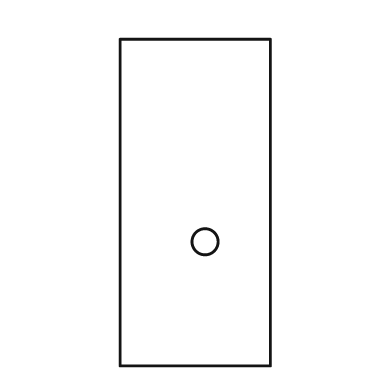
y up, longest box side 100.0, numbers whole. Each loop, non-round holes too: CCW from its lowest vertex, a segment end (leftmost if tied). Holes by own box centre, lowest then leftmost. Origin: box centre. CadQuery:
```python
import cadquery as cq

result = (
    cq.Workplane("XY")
    .moveTo(-23.0, -50.0)
    .lineTo(23.0, -50.0)
    .lineTo(23.0, 50.0)
    .lineTo(-23.0, 50.0)
    .close()
    .moveTo(3.0, -12.0)
    .circle(4.0)
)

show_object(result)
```